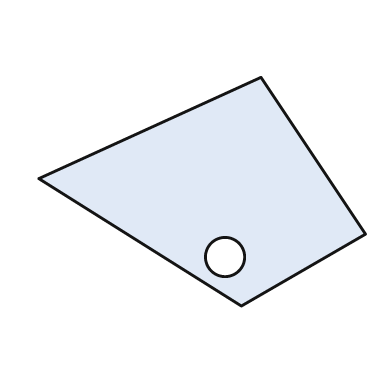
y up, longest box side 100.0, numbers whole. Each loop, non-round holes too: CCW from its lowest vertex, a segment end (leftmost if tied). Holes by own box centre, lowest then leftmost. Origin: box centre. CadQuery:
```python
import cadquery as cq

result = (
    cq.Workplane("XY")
    .moveTo(12.0, -35.0)
    .lineTo(50.0, -13.0)
    .lineTo(18.0, 35.0)
    .lineTo(-50.0, 4.0)
    .close()
    .moveTo(7.0, -20.0)
    .circle(6.0)
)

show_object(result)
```